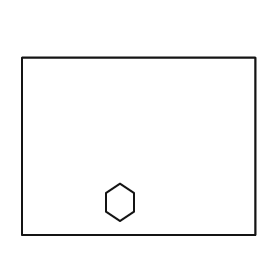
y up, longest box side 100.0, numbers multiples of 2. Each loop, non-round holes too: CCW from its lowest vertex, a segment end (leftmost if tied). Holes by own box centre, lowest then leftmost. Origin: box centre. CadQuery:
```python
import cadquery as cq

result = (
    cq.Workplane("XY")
    .moveTo(-50.0, -38.0)
    .lineTo(50.0, -38.0)
    .lineTo(50.0, 38.0)
    .lineTo(-50.0, 38.0)
    .close()
    .moveTo(-8.0, -32.0)
    .lineTo(-2.0, -28.0)
    .lineTo(-2.0, -20.0)
    .lineTo(-8.0, -16.0)
    .lineTo(-14.0, -20.0)
    .lineTo(-14.0, -28.0)
    .close()
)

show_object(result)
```